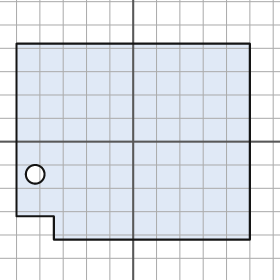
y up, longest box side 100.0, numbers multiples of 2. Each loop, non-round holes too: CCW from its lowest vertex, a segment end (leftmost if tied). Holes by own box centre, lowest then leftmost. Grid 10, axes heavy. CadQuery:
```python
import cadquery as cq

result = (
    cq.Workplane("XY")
    .moveTo(-34.0, -42.0)
    .lineTo(50.0, -42.0)
    .lineTo(50.0, 42.0)
    .lineTo(-50.0, 42.0)
    .lineTo(-50.0, -32.0)
    .lineTo(-34.0, -32.0)
    .close()
    .moveTo(-42.0, -14.0)
    .circle(4.0)
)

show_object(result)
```